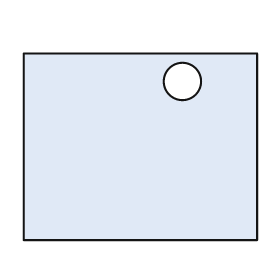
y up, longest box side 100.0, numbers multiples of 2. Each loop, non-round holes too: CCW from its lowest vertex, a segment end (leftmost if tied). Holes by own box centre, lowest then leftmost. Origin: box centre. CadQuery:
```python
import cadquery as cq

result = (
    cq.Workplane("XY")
    .moveTo(-50.0, -40.0)
    .lineTo(50.0, -40.0)
    .lineTo(50.0, 40.0)
    .lineTo(-50.0, 40.0)
    .close()
    .moveTo(18.0, 28.0)
    .circle(8.0)
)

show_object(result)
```